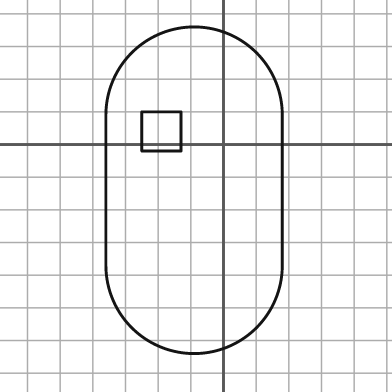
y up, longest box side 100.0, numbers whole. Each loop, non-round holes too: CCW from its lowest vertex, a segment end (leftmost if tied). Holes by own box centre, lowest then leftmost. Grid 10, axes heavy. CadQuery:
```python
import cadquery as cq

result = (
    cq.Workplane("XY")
    .moveTo(-36.0, -37.0)
    .threePointArc((-9.0, -64.0), (18.0, -37.0))
    .lineTo(18.0, 9.0)
    .threePointArc((-9.0, 36.0), (-36.0, 9.0))
    .close()
    .moveTo(-25.0, -2.0)
    .lineTo(-13.0, -2.0)
    .lineTo(-13.0, 10.0)
    .lineTo(-25.0, 10.0)
    .close()
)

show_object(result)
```